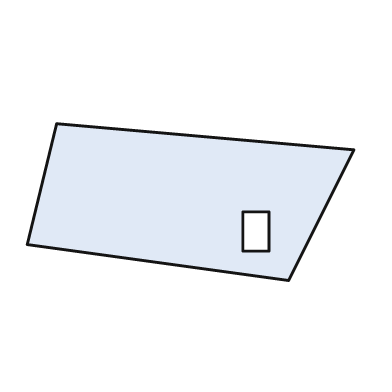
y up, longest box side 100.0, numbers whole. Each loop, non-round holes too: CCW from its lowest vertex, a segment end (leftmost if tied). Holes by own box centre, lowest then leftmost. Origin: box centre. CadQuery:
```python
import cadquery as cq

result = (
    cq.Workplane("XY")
    .moveTo(30.0, -24.0)
    .lineTo(50.0, 16.0)
    .lineTo(-41.0, 24.0)
    .lineTo(-50.0, -13.0)
    .close()
    .moveTo(16.0, -15.0)
    .lineTo(24.0, -15.0)
    .lineTo(24.0, -3.0)
    .lineTo(16.0, -3.0)
    .close()
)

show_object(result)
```